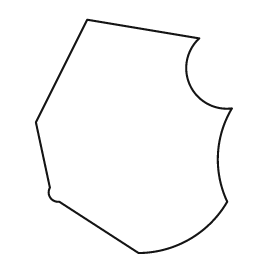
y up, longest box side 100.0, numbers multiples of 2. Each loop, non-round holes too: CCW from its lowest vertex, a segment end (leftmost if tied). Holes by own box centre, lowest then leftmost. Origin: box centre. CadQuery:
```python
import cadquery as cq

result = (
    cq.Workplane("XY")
    .moveTo(2.0, -50.0)
    .threePointArc((24.0, -44.0), (40.0, -28.0))
    .threePointArc((36.0, -8.0), (42.0, 12.0))
    .threePointArc((24.0, 22.0), (28.0, 42.0))
    .lineTo(-20.0, 50.0)
    .lineTo(-42.0, 6.0)
    .lineTo(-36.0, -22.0)
    .threePointArc((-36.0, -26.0), (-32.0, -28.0))
    .close()
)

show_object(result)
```